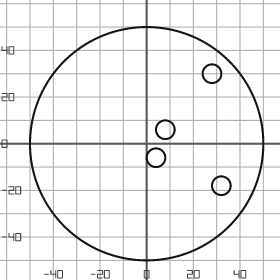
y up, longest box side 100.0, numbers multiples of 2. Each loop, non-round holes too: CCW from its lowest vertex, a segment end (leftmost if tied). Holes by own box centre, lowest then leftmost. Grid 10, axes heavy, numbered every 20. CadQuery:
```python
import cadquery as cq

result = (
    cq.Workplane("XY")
    .moveTo(0.0, 0.0)
    .circle(50.0)
    .moveTo(32.0, -18.0)
    .circle(4.0)
    .moveTo(4.0, -6.0)
    .circle(4.0)
    .moveTo(8.0, 6.0)
    .circle(4.0)
    .moveTo(28.0, 30.0)
    .circle(4.0)
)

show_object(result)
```